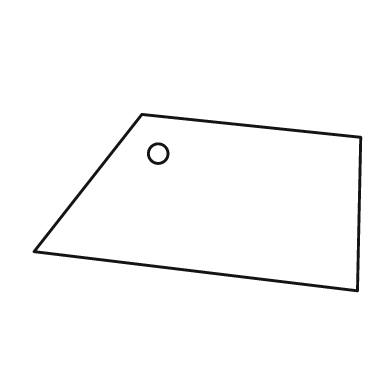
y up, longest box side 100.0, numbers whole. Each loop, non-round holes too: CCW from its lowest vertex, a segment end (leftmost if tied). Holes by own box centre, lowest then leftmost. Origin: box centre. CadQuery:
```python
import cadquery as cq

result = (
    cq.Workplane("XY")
    .moveTo(49.0, -27.0)
    .lineTo(50.0, 20.0)
    .lineTo(-17.0, 27.0)
    .lineTo(-50.0, -15.0)
    .close()
    .moveTo(-12.0, 15.0)
    .circle(3.0)
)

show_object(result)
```